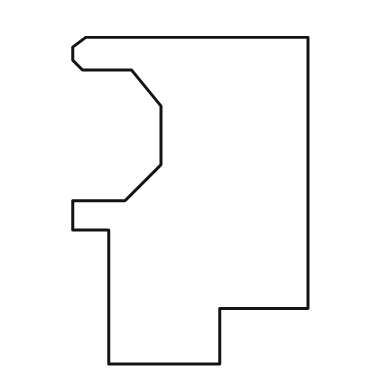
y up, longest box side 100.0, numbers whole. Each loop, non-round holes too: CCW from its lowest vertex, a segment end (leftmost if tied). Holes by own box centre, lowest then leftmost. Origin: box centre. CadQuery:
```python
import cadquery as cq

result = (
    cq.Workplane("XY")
    .moveTo(-25.0, -50.0)
    .lineTo(9.0, -50.0)
    .lineTo(9.0, -33.0)
    .lineTo(36.0, -33.0)
    .lineTo(36.0, 50.0)
    .lineTo(-32.0, 50.0)
    .lineTo(-36.0, 47.0)
    .lineTo(-36.0, 43.0)
    .lineTo(-33.0, 40.0)
    .lineTo(-18.0, 40.0)
    .lineTo(-9.0, 29.0)
    .lineTo(-9.0, 11.0)
    .lineTo(-20.0, 0.0)
    .lineTo(-36.0, 0.0)
    .lineTo(-36.0, -9.0)
    .lineTo(-25.0, -9.0)
    .close()
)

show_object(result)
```